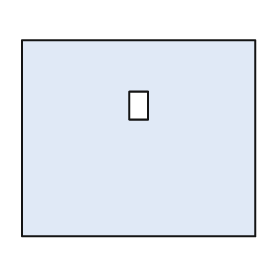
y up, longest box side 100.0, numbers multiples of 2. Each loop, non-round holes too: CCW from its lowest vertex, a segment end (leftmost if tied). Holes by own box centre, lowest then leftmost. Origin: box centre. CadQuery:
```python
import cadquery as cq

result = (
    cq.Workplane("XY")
    .moveTo(-50.0, -42.0)
    .lineTo(50.0, -42.0)
    .lineTo(50.0, 42.0)
    .lineTo(-50.0, 42.0)
    .close()
    .moveTo(-4.0, 8.0)
    .lineTo(4.0, 8.0)
    .lineTo(4.0, 20.0)
    .lineTo(-4.0, 20.0)
    .close()
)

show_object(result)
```